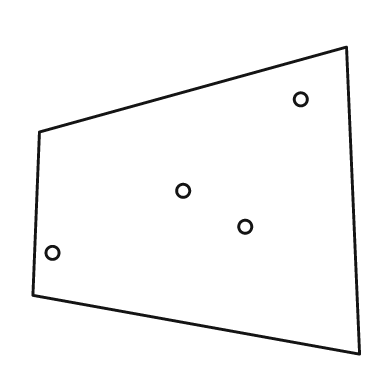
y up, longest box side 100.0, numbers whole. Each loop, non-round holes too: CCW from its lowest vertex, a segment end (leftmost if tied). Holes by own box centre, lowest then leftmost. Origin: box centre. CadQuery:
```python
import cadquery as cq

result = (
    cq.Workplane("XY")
    .moveTo(50.0, -47.0)
    .lineTo(46.0, 47.0)
    .lineTo(-48.0, 21.0)
    .lineTo(-50.0, -29.0)
    .close()
    .moveTo(-44.0, -16.0)
    .circle(2.0)
    .moveTo(15.0, -8.0)
    .circle(2.0)
    .moveTo(-4.0, 3.0)
    .circle(2.0)
    .moveTo(32.0, 31.0)
    .circle(2.0)
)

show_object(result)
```